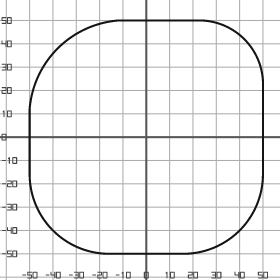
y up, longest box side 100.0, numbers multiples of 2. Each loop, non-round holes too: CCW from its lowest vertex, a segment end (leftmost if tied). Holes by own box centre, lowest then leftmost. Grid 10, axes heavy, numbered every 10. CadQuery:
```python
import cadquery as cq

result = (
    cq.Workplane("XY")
    .moveTo(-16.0, -50.0)
    .lineTo(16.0, -50.0)
    .threePointArc((40.0, -40.0), (50.0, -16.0))
    .lineTo(50.0, 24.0)
    .threePointArc((42.0, 42.0), (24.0, 50.0))
    .lineTo(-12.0, 50.0)
    .threePointArc((-38.0, 38.0), (-50.0, 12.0))
    .lineTo(-50.0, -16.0)
    .threePointArc((-40.0, -40.0), (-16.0, -50.0))
    .close()
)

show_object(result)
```